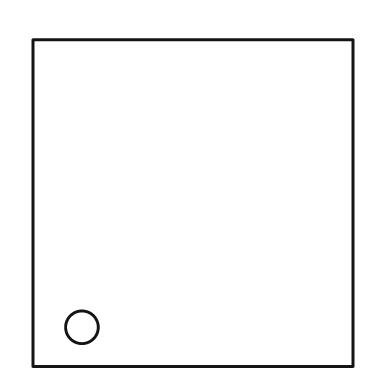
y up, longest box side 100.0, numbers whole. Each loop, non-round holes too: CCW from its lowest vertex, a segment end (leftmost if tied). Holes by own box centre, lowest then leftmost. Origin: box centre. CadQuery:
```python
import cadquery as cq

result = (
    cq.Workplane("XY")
    .moveTo(-49.0, -50.0)
    .lineTo(49.0, -50.0)
    .lineTo(49.0, 50.0)
    .lineTo(-49.0, 50.0)
    .close()
    .moveTo(-34.0, -38.0)
    .circle(5.0)
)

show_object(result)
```